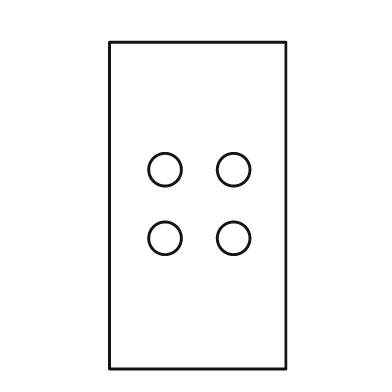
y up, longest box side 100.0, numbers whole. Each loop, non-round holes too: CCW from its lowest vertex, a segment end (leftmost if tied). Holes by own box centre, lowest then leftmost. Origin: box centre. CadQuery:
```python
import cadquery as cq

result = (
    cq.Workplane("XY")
    .moveTo(-27.0, -50.0)
    .lineTo(27.0, -50.0)
    .lineTo(27.0, 50.0)
    .lineTo(-27.0, 50.0)
    .close()
    .moveTo(-10.0, -10.0)
    .circle(5.0)
    .moveTo(11.0, -10.0)
    .circle(5.0)
    .moveTo(-10.0, 11.0)
    .circle(5.0)
    .moveTo(11.0, 11.0)
    .circle(5.0)
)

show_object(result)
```